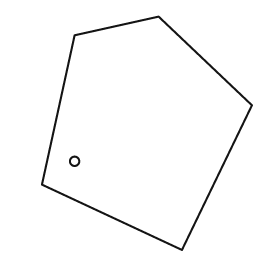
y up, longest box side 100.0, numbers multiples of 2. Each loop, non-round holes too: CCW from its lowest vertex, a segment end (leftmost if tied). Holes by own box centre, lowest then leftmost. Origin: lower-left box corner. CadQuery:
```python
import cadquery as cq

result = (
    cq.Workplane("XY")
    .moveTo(60.0, 0.0)
    .lineTo(90.0, 62.0)
    .lineTo(50.0, 100.0)
    .lineTo(14.0, 92.0)
    .lineTo(0.0, 28.0)
    .close()
    .moveTo(14.0, 38.0)
    .circle(2.0)
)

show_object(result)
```